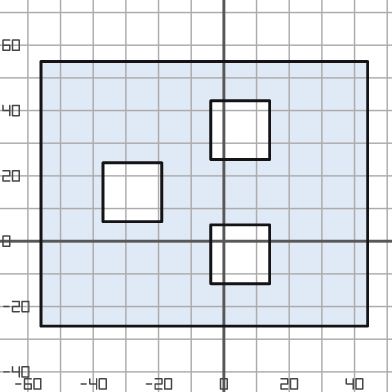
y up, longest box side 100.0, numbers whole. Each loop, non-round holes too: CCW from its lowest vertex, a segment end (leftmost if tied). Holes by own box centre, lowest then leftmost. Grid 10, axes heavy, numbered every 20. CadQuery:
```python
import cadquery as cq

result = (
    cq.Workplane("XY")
    .moveTo(-56.0, -26.0)
    .lineTo(44.0, -26.0)
    .lineTo(44.0, 55.0)
    .lineTo(-56.0, 55.0)
    .close()
    .moveTo(-4.0, -13.0)
    .lineTo(14.0, -13.0)
    .lineTo(14.0, 5.0)
    .lineTo(-4.0, 5.0)
    .close()
    .moveTo(-37.0, 6.0)
    .lineTo(-19.0, 6.0)
    .lineTo(-19.0, 24.0)
    .lineTo(-37.0, 24.0)
    .close()
    .moveTo(-4.0, 25.0)
    .lineTo(14.0, 25.0)
    .lineTo(14.0, 43.0)
    .lineTo(-4.0, 43.0)
    .close()
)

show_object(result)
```